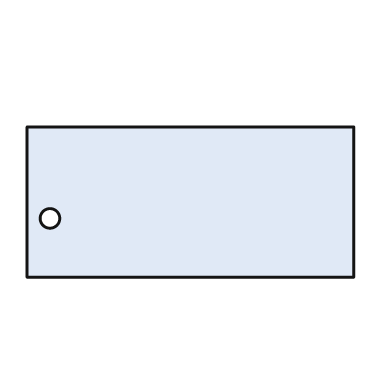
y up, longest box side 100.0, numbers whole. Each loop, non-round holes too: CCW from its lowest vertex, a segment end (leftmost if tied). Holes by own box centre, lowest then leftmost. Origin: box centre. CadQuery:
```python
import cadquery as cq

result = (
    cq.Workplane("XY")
    .moveTo(-50.0, -23.0)
    .lineTo(50.0, -23.0)
    .lineTo(50.0, 23.0)
    .lineTo(-50.0, 23.0)
    .close()
    .moveTo(-43.0, -5.0)
    .circle(3.0)
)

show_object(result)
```